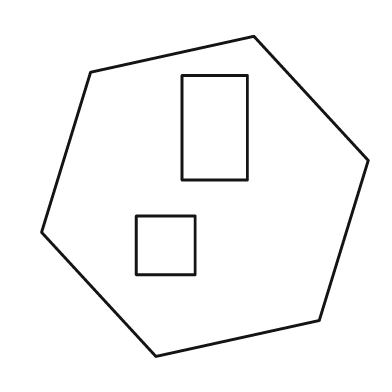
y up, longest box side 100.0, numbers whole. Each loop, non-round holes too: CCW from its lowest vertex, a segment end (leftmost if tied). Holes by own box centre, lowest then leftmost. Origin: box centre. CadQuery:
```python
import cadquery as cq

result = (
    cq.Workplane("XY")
    .moveTo(-15.0, -49.0)
    .lineTo(35.0, -38.0)
    .lineTo(50.0, 11.0)
    .lineTo(15.0, 49.0)
    .lineTo(-35.0, 38.0)
    .lineTo(-50.0, -11.0)
    .close()
    .moveTo(-21.0, -24.0)
    .lineTo(-3.0, -24.0)
    .lineTo(-3.0, -6.0)
    .lineTo(-21.0, -6.0)
    .close()
    .moveTo(-7.0, 5.0)
    .lineTo(13.0, 5.0)
    .lineTo(13.0, 37.0)
    .lineTo(-7.0, 37.0)
    .close()
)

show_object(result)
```